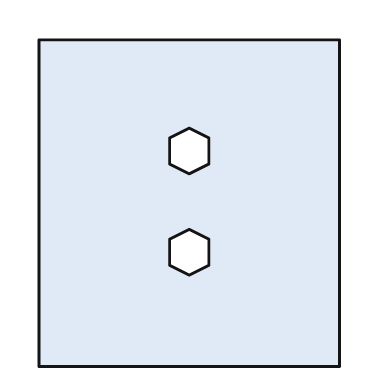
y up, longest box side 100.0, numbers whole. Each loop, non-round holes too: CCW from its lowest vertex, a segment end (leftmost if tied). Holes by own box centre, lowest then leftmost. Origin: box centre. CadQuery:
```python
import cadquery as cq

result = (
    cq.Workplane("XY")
    .moveTo(-46.0, -50.0)
    .lineTo(46.0, -50.0)
    .lineTo(46.0, 50.0)
    .lineTo(-46.0, 50.0)
    .close()
    .moveTo(0.0, -22.0)
    .lineTo(6.0, -19.0)
    .lineTo(6.0, -11.0)
    .lineTo(0.0, -8.0)
    .lineTo(-6.0, -11.0)
    .lineTo(-6.0, -19.0)
    .close()
    .moveTo(0.0, 9.0)
    .lineTo(6.0, 12.0)
    .lineTo(6.0, 20.0)
    .lineTo(0.0, 23.0)
    .lineTo(-6.0, 20.0)
    .lineTo(-6.0, 12.0)
    .close()
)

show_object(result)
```